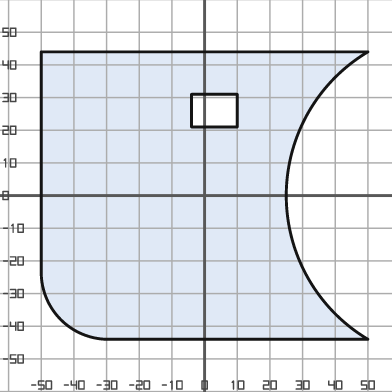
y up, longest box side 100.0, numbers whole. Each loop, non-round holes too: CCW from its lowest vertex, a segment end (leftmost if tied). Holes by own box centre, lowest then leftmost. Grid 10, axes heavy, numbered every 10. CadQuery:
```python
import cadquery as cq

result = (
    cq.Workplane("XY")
    .moveTo(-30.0, -44.0)
    .lineTo(50.0, -44.0)
    .threePointArc((25.0, 0.0), (50.0, 44.0))
    .lineTo(-50.0, 44.0)
    .lineTo(-50.0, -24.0)
    .threePointArc((-44.0, -38.0), (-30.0, -44.0))
    .close()
    .moveTo(-4.0, 21.0)
    .lineTo(10.0, 21.0)
    .lineTo(10.0, 31.0)
    .lineTo(-4.0, 31.0)
    .close()
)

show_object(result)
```